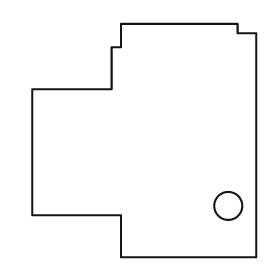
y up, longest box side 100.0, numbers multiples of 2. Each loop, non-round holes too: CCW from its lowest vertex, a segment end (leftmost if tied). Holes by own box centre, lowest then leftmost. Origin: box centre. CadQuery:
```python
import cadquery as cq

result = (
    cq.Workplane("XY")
    .moveTo(-10.0, -50.0)
    .lineTo(48.0, -50.0)
    .lineTo(48.0, 46.0)
    .lineTo(40.0, 46.0)
    .lineTo(40.0, 50.0)
    .lineTo(-10.0, 50.0)
    .lineTo(-10.0, 40.0)
    .lineTo(-14.0, 40.0)
    .lineTo(-14.0, 22.0)
    .lineTo(-48.0, 22.0)
    .lineTo(-48.0, -32.0)
    .lineTo(-10.0, -32.0)
    .close()
    .moveTo(36.0, -28.0)
    .circle(6.0)
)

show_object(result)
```